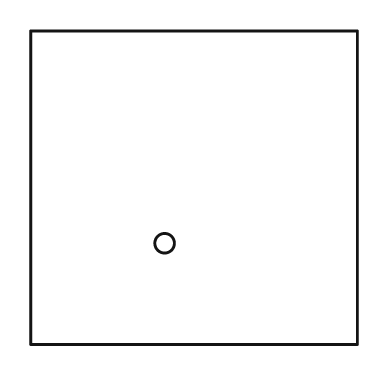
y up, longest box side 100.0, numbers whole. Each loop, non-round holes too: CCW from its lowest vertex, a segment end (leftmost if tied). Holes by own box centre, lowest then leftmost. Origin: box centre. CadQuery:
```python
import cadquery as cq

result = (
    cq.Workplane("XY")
    .moveTo(-50.0, -48.0)
    .lineTo(50.0, -48.0)
    .lineTo(50.0, 48.0)
    .lineTo(-50.0, 48.0)
    .close()
    .moveTo(-9.0, -17.0)
    .circle(3.0)
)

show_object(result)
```